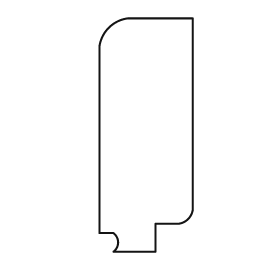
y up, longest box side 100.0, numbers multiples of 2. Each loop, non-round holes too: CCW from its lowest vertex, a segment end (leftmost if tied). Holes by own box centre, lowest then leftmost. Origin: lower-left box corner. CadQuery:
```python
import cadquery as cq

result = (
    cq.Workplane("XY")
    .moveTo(6.0, 0.0)
    .lineTo(24.0, 0.0)
    .lineTo(24.0, 12.0)
    .lineTo(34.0, 12.0)
    .threePointArc((38.0, 14.0), (40.0, 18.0))
    .lineTo(40.0, 100.0)
    .lineTo(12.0, 100.0)
    .threePointArc((4.0, 96.0), (0.0, 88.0))
    .lineTo(0.0, 8.0)
    .lineTo(6.0, 8.0)
    .threePointArc((8.0, 4.0), (6.0, 0.0))
    .close()
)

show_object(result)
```